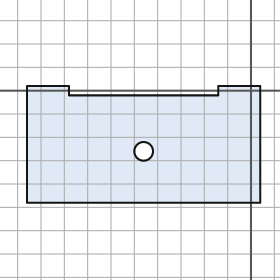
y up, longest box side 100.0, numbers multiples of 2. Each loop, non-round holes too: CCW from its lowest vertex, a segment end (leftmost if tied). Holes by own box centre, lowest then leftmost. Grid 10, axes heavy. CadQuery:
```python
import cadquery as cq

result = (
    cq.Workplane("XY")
    .moveTo(-96.0, -48.0)
    .lineTo(4.0, -48.0)
    .lineTo(4.0, 2.0)
    .lineTo(-14.0, 2.0)
    .lineTo(-14.0, -2.0)
    .lineTo(-78.0, -2.0)
    .lineTo(-78.0, 2.0)
    .lineTo(-96.0, 2.0)
    .close()
    .moveTo(-46.0, -26.0)
    .circle(4.0)
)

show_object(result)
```